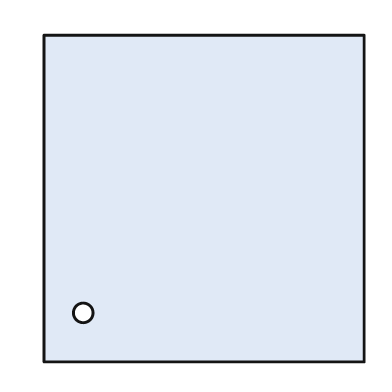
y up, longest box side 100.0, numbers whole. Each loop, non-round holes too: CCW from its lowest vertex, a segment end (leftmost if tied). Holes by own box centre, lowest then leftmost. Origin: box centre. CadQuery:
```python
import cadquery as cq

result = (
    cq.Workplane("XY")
    .moveTo(-49.0, -50.0)
    .lineTo(49.0, -50.0)
    .lineTo(49.0, 50.0)
    .lineTo(-49.0, 50.0)
    .close()
    .moveTo(-37.0, -35.0)
    .circle(3.0)
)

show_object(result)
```